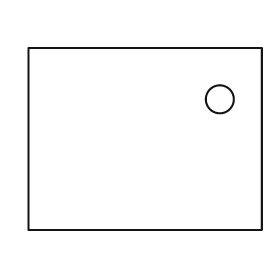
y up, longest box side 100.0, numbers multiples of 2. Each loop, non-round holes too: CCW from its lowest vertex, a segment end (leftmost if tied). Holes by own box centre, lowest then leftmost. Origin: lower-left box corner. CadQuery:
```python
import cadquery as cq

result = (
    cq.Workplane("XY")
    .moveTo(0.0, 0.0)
    .lineTo(100.0, 0.0)
    .lineTo(100.0, 78.0)
    .lineTo(0.0, 78.0)
    .close()
    .moveTo(82.0, 56.0)
    .circle(6.0)
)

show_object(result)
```